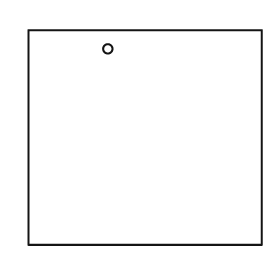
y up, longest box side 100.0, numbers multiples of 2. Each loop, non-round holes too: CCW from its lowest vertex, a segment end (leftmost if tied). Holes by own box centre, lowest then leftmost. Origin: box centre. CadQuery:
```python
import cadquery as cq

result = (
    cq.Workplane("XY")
    .moveTo(-50.0, -46.0)
    .lineTo(50.0, -46.0)
    .lineTo(50.0, 46.0)
    .lineTo(-50.0, 46.0)
    .close()
    .moveTo(-16.0, 38.0)
    .circle(2.0)
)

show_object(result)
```